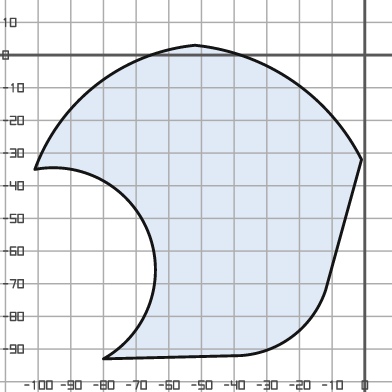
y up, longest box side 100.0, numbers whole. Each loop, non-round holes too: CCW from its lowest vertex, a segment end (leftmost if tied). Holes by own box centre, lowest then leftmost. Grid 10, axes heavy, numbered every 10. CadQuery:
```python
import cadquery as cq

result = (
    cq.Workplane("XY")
    .moveTo(-80.0, -93.0)
    .lineTo(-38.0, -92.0)
    .threePointArc((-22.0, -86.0), (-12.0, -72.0))
    .lineTo(-1.0, -32.0)
    .threePointArc((-22.0, -8.0), (-52.0, 3.0))
    .threePointArc((-82.0, -9.0), (-101.0, -35.0))
    .threePointArc((-66.0, -55.0), (-80.0, -93.0))
    .close()
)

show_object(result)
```